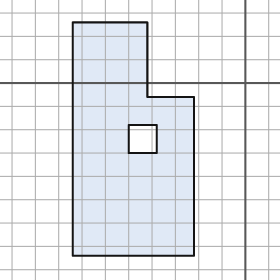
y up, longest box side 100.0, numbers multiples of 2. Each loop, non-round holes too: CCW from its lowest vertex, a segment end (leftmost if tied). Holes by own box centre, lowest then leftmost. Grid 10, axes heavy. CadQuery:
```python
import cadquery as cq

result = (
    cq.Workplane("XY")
    .moveTo(-74.0, -74.0)
    .lineTo(-22.0, -74.0)
    .lineTo(-22.0, -6.0)
    .lineTo(-42.0, -6.0)
    .lineTo(-42.0, 26.0)
    .lineTo(-74.0, 26.0)
    .close()
    .moveTo(-50.0, -30.0)
    .lineTo(-38.0, -30.0)
    .lineTo(-38.0, -18.0)
    .lineTo(-50.0, -18.0)
    .close()
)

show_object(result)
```